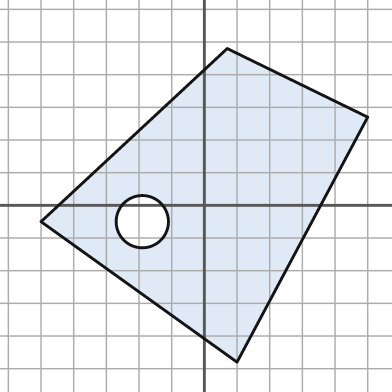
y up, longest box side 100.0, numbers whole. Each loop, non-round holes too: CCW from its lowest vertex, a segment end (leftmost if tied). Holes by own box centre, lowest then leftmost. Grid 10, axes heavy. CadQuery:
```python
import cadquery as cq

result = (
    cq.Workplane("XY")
    .moveTo(10.0, -48.0)
    .lineTo(50.0, 27.0)
    .lineTo(7.0, 48.0)
    .lineTo(-50.0, -5.0)
    .close()
    .moveTo(-19.0, -5.0)
    .circle(8.0)
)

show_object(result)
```